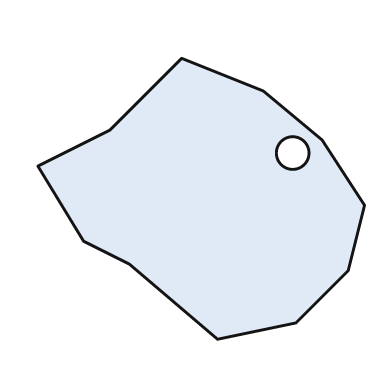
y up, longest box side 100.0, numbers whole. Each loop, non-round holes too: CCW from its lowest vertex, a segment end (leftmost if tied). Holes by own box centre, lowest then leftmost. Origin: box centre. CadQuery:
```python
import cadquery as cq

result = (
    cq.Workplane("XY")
    .moveTo(5.0, -43.0)
    .lineTo(29.0, -38.0)
    .lineTo(45.0, -22.0)
    .lineTo(50.0, -2.0)
    .lineTo(37.0, 18.0)
    .lineTo(19.0, 33.0)
    .lineTo(-6.0, 43.0)
    .lineTo(-28.0, 21.0)
    .lineTo(-50.0, 10.0)
    .lineTo(-36.0, -13.0)
    .lineTo(-22.0, -20.0)
    .close()
    .moveTo(28.0, 14.0)
    .circle(5.0)
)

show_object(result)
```